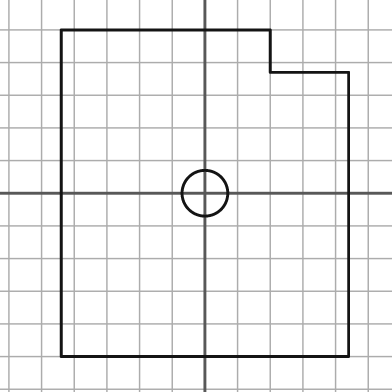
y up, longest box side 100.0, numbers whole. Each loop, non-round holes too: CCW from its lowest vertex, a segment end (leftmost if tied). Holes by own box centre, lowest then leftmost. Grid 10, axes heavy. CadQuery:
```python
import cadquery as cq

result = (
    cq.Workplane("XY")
    .moveTo(-44.0, -50.0)
    .lineTo(44.0, -50.0)
    .lineTo(44.0, 37.0)
    .lineTo(20.0, 37.0)
    .lineTo(20.0, 50.0)
    .lineTo(-44.0, 50.0)
    .close()
    .moveTo(0.0, 0.0)
    .circle(7.0)
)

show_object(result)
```